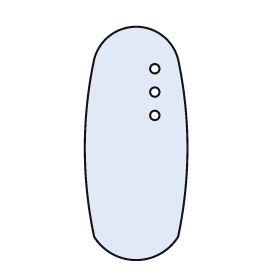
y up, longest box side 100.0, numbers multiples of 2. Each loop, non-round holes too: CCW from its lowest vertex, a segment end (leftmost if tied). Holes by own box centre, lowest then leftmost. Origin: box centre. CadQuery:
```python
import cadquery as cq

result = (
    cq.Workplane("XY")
    .moveTo(-18.0, -40.0)
    .threePointArc((0.0, -50.0), (18.0, -40.0))
    .threePointArc((22.0, -2.0), (18.0, 36.0))
    .threePointArc((0.0, 50.0), (-18.0, 36.0))
    .threePointArc((-22.0, -2.0), (-18.0, -40.0))
    .close()
    .moveTo(8.0, 12.0)
    .circle(2.0)
    .moveTo(8.0, 22.0)
    .circle(2.0)
    .moveTo(8.0, 32.0)
    .circle(2.0)
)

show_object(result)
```